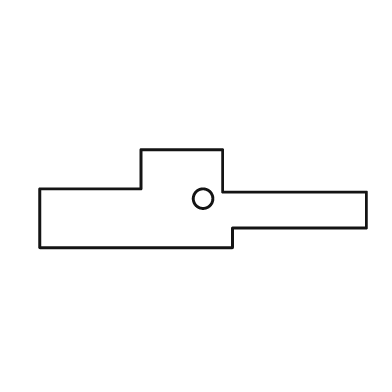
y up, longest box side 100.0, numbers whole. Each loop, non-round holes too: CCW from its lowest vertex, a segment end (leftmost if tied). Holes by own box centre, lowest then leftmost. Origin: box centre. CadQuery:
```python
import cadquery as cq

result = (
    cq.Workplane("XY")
    .moveTo(-50.0, -15.0)
    .lineTo(9.0, -15.0)
    .lineTo(9.0, -9.0)
    .lineTo(50.0, -9.0)
    .lineTo(50.0, 2.0)
    .lineTo(6.0, 2.0)
    .lineTo(6.0, 15.0)
    .lineTo(-19.0, 15.0)
    .lineTo(-19.0, 3.0)
    .lineTo(-50.0, 3.0)
    .close()
    .moveTo(0.0, 0.0)
    .circle(3.0)
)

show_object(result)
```